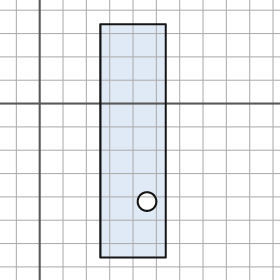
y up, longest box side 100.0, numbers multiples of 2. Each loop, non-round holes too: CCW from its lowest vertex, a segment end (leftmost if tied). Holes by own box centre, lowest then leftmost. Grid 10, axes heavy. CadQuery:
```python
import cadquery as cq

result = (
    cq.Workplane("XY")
    .moveTo(26.0, -66.0)
    .lineTo(54.0, -66.0)
    .lineTo(54.0, 34.0)
    .lineTo(26.0, 34.0)
    .close()
    .moveTo(46.0, -42.0)
    .circle(4.0)
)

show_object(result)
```